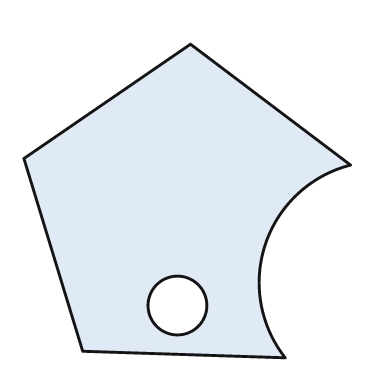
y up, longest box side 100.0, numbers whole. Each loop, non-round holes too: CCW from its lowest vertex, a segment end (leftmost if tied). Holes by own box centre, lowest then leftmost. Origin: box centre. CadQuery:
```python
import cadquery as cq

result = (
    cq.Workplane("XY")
    .moveTo(30.0, -48.0)
    .threePointArc((24.0, -13.0), (50.0, 11.0))
    .lineTo(1.0, 48.0)
    .lineTo(-50.0, 13.0)
    .lineTo(-32.0, -46.0)
    .close()
    .moveTo(-3.0, -32.0)
    .circle(9.0)
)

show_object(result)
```